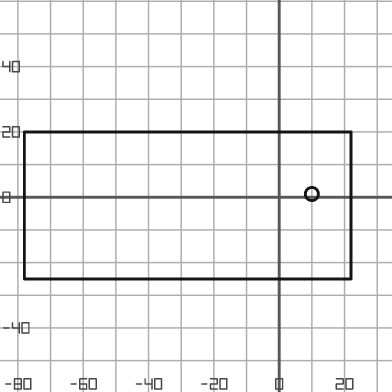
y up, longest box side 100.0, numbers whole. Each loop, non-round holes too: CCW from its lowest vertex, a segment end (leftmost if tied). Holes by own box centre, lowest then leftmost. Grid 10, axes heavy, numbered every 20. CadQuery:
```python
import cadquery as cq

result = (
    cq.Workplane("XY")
    .moveTo(-78.0, -25.0)
    .lineTo(22.0, -25.0)
    .lineTo(22.0, 20.0)
    .lineTo(-78.0, 20.0)
    .close()
    .moveTo(10.0, 1.0)
    .circle(2.0)
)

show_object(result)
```